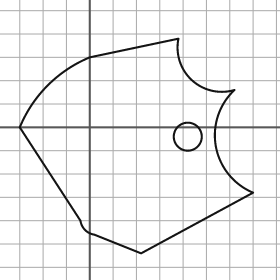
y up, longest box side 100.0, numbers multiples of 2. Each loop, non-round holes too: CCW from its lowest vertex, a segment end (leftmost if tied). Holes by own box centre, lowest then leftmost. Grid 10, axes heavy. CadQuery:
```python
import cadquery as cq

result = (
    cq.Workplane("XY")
    .moveTo(22.0, -54.0)
    .lineTo(70.0, -28.0)
    .threePointArc((54.0, -8.0), (62.0, 16.0))
    .threePointArc((44.0, 20.0), (38.0, 38.0))
    .lineTo(0.0, 30.0)
    .threePointArc((-18.0, 18.0), (-30.0, 0.0))
    .lineTo(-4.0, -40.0)
    .threePointArc((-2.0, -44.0), (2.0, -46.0))
    .close()
    .moveTo(42.0, -4.0)
    .circle(6.0)
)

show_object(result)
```